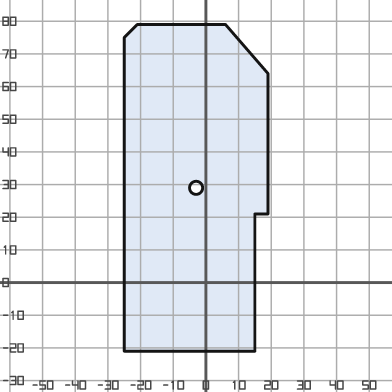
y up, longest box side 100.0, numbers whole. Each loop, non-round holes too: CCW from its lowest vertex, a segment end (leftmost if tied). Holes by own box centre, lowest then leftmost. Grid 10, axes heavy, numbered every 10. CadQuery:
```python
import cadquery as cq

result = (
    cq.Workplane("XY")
    .moveTo(-25.0, -21.0)
    .lineTo(15.0, -21.0)
    .lineTo(15.0, 21.0)
    .lineTo(19.0, 21.0)
    .lineTo(19.0, 64.0)
    .lineTo(6.0, 79.0)
    .lineTo(-21.0, 79.0)
    .lineTo(-25.0, 75.0)
    .close()
    .moveTo(-3.0, 29.0)
    .circle(2.0)
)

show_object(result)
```